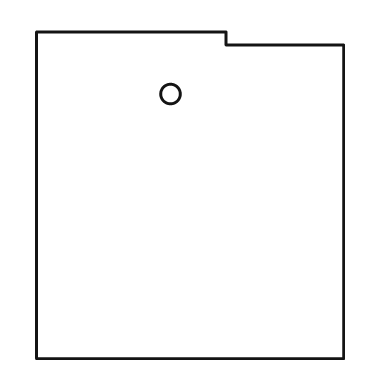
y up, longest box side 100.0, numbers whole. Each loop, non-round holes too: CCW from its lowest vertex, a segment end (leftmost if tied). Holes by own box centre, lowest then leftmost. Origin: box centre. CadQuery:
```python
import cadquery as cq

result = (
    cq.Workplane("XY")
    .moveTo(-47.0, -50.0)
    .lineTo(47.0, -50.0)
    .lineTo(47.0, 46.0)
    .lineTo(11.0, 46.0)
    .lineTo(11.0, 50.0)
    .lineTo(-47.0, 50.0)
    .close()
    .moveTo(-6.0, 31.0)
    .circle(3.0)
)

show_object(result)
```